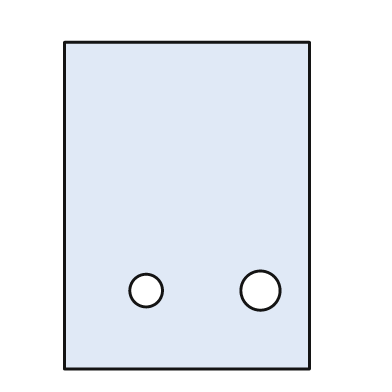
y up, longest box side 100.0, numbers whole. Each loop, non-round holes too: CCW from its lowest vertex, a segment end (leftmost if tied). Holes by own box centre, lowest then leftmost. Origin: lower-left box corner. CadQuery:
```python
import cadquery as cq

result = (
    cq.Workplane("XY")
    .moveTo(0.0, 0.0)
    .lineTo(75.0, 0.0)
    .lineTo(75.0, 100.0)
    .lineTo(0.0, 100.0)
    .close()
    .moveTo(25.0, 24.0)
    .circle(5.0)
    .moveTo(60.0, 24.0)
    .circle(6.0)
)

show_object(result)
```